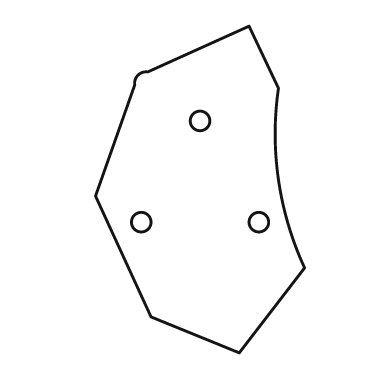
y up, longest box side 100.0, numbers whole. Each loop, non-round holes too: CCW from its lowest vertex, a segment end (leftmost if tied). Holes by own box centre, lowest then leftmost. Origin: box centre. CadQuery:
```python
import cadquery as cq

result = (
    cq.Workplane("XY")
    .moveTo(12.0, -50.0)
    .lineTo(32.0, -24.0)
    .threePointArc((24.0, 3.0), (24.0, 31.0))
    .lineTo(15.0, 50.0)
    .lineTo(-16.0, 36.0)
    .threePointArc((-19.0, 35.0), (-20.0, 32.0))
    .lineTo(-32.0, -2.0)
    .lineTo(-15.0, -39.0)
    .close()
    .moveTo(-18.0, -10.0)
    .circle(3.0)
    .moveTo(18.0, -10.0)
    .circle(3.0)
    .moveTo(0.0, 21.0)
    .circle(3.0)
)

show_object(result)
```